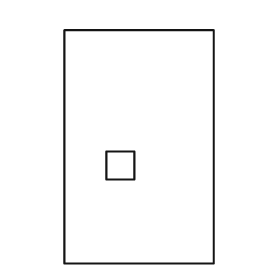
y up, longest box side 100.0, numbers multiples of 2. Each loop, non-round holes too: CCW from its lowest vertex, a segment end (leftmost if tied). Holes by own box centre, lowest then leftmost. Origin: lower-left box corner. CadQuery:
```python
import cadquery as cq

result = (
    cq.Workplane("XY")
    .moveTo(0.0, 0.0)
    .lineTo(64.0, 0.0)
    .lineTo(64.0, 100.0)
    .lineTo(0.0, 100.0)
    .close()
    .moveTo(18.0, 36.0)
    .lineTo(30.0, 36.0)
    .lineTo(30.0, 48.0)
    .lineTo(18.0, 48.0)
    .close()
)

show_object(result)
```